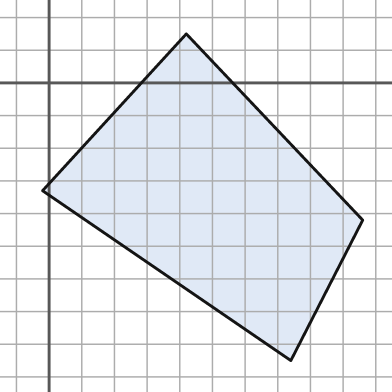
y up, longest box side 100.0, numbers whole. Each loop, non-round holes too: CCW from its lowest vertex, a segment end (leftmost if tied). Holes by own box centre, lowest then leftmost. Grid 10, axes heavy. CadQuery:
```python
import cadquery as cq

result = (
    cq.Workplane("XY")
    .moveTo(74.0, -85.0)
    .lineTo(96.0, -42.0)
    .lineTo(42.0, 15.0)
    .lineTo(-2.0, -33.0)
    .close()
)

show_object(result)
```